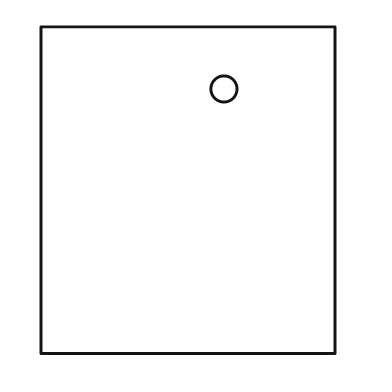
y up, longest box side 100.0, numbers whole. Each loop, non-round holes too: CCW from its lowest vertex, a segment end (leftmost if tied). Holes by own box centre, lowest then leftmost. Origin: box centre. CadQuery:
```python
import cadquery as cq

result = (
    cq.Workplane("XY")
    .moveTo(-45.0, -50.0)
    .lineTo(45.0, -50.0)
    .lineTo(45.0, 50.0)
    .lineTo(-45.0, 50.0)
    .close()
    .moveTo(11.0, 31.0)
    .circle(4.0)
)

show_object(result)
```